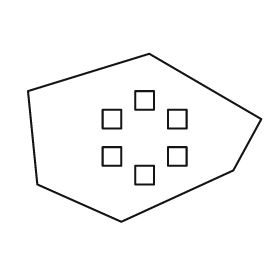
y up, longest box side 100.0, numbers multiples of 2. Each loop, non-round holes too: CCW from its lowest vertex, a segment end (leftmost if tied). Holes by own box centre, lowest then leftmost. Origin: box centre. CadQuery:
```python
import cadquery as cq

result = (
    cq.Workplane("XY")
    .moveTo(-10.0, -36.0)
    .lineTo(38.0, -14.0)
    .lineTo(50.0, 8.0)
    .lineTo(2.0, 36.0)
    .lineTo(-50.0, 20.0)
    .lineTo(-46.0, -20.0)
    .close()
    .moveTo(-4.0, -20.0)
    .lineTo(4.0, -20.0)
    .lineTo(4.0, -12.0)
    .lineTo(-4.0, -12.0)
    .close()
    .moveTo(-18.0, -12.0)
    .lineTo(-10.0, -12.0)
    .lineTo(-10.0, -4.0)
    .lineTo(-18.0, -4.0)
    .close()
    .moveTo(10.0, -12.0)
    .lineTo(18.0, -12.0)
    .lineTo(18.0, -4.0)
    .lineTo(10.0, -4.0)
    .close()
    .moveTo(-18.0, 4.0)
    .lineTo(-10.0, 4.0)
    .lineTo(-10.0, 12.0)
    .lineTo(-18.0, 12.0)
    .close()
    .moveTo(10.0, 4.0)
    .lineTo(18.0, 4.0)
    .lineTo(18.0, 12.0)
    .lineTo(10.0, 12.0)
    .close()
    .moveTo(-4.0, 12.0)
    .lineTo(4.0, 12.0)
    .lineTo(4.0, 20.0)
    .lineTo(-4.0, 20.0)
    .close()
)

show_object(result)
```